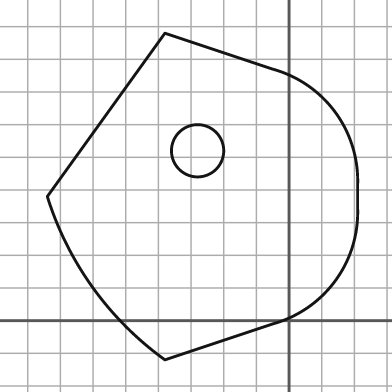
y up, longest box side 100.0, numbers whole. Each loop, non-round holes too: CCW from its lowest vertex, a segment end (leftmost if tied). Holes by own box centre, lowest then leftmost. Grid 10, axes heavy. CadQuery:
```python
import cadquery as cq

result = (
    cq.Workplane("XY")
    .moveTo(-38.0, -12.0)
    .lineTo(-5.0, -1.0)
    .threePointArc((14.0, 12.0), (21.0, 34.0))
    .lineTo(21.0, 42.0)
    .threePointArc((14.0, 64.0), (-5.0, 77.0))
    .lineTo(-38.0, 88.0)
    .lineTo(-74.0, 38.0)
    .threePointArc((-60.0, 10.0), (-38.0, -12.0))
    .close()
    .moveTo(-28.0, 52.0)
    .circle(8.0)
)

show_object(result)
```